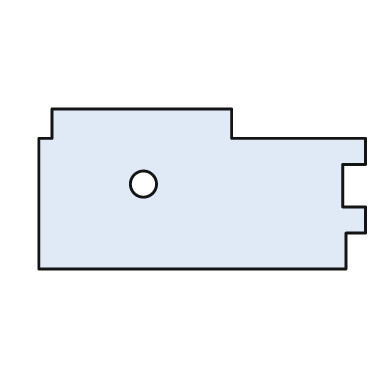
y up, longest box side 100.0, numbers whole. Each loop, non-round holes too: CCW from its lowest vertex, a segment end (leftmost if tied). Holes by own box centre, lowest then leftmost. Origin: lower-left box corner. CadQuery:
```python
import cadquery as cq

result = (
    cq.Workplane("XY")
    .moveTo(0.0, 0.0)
    .lineTo(94.0, 0.0)
    .lineTo(94.0, 11.0)
    .lineTo(100.0, 11.0)
    .lineTo(100.0, 19.0)
    .lineTo(93.0, 19.0)
    .lineTo(93.0, 32.0)
    .lineTo(100.0, 32.0)
    .lineTo(100.0, 40.0)
    .lineTo(59.0, 40.0)
    .lineTo(59.0, 49.0)
    .lineTo(4.0, 49.0)
    .lineTo(4.0, 40.0)
    .lineTo(0.0, 40.0)
    .close()
    .moveTo(32.0, 26.0)
    .circle(4.0)
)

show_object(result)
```